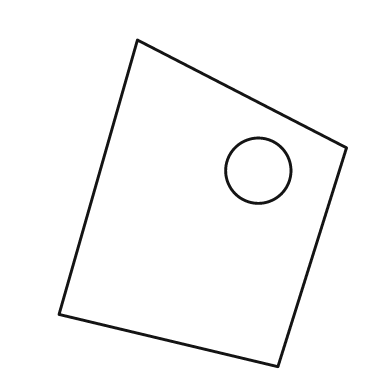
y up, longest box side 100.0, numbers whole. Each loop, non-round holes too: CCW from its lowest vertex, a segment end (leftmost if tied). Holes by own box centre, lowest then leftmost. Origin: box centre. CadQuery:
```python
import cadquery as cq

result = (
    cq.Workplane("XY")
    .moveTo(23.0, -50.0)
    .lineTo(44.0, 17.0)
    .lineTo(-20.0, 50.0)
    .lineTo(-44.0, -34.0)
    .close()
    .moveTo(17.0, 10.0)
    .circle(10.0)
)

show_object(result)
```